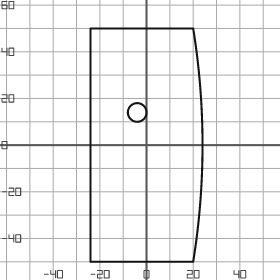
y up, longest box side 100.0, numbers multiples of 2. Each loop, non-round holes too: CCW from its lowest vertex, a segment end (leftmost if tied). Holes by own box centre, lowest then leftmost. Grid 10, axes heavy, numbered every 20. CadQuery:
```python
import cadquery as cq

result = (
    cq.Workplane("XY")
    .moveTo(-24.0, -50.0)
    .lineTo(20.0, -50.0)
    .threePointArc((24.0, 0.0), (20.0, 50.0))
    .lineTo(-24.0, 50.0)
    .close()
    .moveTo(-4.0, 14.0)
    .circle(4.0)
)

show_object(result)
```